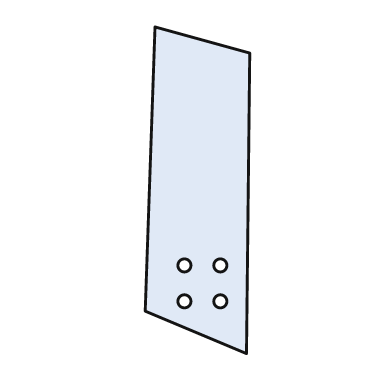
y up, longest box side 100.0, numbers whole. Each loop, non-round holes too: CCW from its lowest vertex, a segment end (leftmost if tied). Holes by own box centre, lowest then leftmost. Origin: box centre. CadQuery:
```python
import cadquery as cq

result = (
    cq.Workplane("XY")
    .moveTo(15.0, -50.0)
    .lineTo(16.0, 42.0)
    .lineTo(-13.0, 50.0)
    .lineTo(-16.0, -37.0)
    .close()
    .moveTo(-4.0, -34.0)
    .circle(2.0)
    .moveTo(7.0, -34.0)
    .circle(2.0)
    .moveTo(-4.0, -23.0)
    .circle(2.0)
    .moveTo(7.0, -23.0)
    .circle(2.0)
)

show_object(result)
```